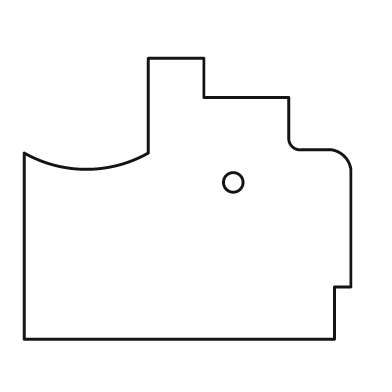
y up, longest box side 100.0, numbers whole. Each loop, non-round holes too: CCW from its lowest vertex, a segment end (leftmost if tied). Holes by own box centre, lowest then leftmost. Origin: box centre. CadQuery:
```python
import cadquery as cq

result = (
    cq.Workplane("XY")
    .moveTo(-50.0, -43.0)
    .lineTo(45.0, -43.0)
    .lineTo(45.0, -27.0)
    .lineTo(50.0, -27.0)
    .lineTo(50.0, 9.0)
    .threePointArc((48.0, 13.0), (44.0, 15.0))
    .lineTo(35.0, 15.0)
    .threePointArc((32.0, 16.0), (31.0, 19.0))
    .lineTo(31.0, 31.0)
    .lineTo(5.0, 31.0)
    .lineTo(5.0, 43.0)
    .lineTo(-12.0, 43.0)
    .lineTo(-12.0, 14.0)
    .threePointArc((-31.0, 9.0), (-50.0, 14.0))
    .close()
    .moveTo(14.0, 5.0)
    .circle(3.0)
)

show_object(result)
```